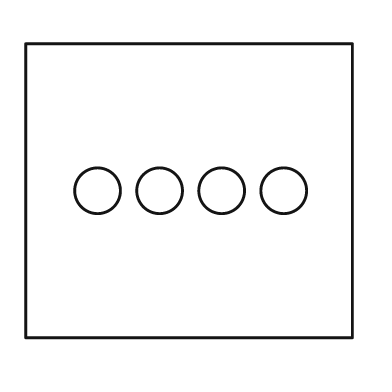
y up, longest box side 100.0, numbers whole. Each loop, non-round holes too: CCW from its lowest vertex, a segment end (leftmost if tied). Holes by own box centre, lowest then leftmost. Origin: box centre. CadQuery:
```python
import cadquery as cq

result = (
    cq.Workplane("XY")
    .moveTo(-50.0, -45.0)
    .lineTo(50.0, -45.0)
    .lineTo(50.0, 45.0)
    .lineTo(-50.0, 45.0)
    .close()
    .moveTo(-28.0, 0.0)
    .circle(7.0)
    .moveTo(-9.0, 0.0)
    .circle(7.0)
    .moveTo(10.0, 0.0)
    .circle(7.0)
    .moveTo(29.0, 0.0)
    .circle(7.0)
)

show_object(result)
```